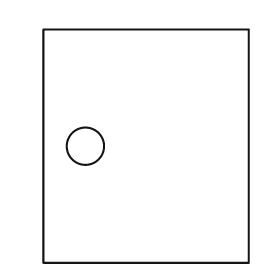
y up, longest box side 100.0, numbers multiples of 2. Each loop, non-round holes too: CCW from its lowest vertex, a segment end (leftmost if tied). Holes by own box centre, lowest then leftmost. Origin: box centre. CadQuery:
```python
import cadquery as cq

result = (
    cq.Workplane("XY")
    .moveTo(-44.0, -50.0)
    .lineTo(44.0, -50.0)
    .lineTo(44.0, 50.0)
    .lineTo(-44.0, 50.0)
    .close()
    .moveTo(-26.0, 0.0)
    .circle(8.0)
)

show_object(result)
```